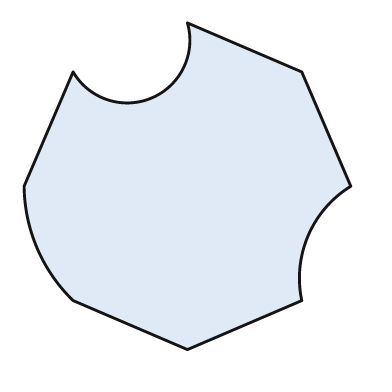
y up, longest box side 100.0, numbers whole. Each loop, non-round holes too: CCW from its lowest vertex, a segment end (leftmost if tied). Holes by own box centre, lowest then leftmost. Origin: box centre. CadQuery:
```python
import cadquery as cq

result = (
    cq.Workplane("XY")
    .moveTo(0.0, -50.0)
    .lineTo(35.0, -35.0)
    .threePointArc((37.0, -15.0), (50.0, 0.0))
    .lineTo(35.0, 35.0)
    .lineTo(0.0, 50.0)
    .threePointArc((-11.0, 27.0), (-35.0, 35.0))
    .lineTo(-50.0, 0.0)
    .threePointArc((-46.0, -19.0), (-35.0, -35.0))
    .close()
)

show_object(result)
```